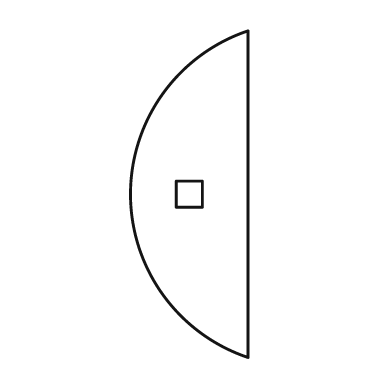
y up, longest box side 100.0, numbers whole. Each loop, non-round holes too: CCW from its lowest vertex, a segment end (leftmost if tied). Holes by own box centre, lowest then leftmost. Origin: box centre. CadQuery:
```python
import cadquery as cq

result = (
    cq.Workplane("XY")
    .moveTo(18.0, -50.0)
    .lineTo(18.0, 50.0)
    .threePointArc((-18.0, 0.0), (18.0, -50.0))
    .close()
    .moveTo(-4.0, -4.0)
    .lineTo(4.0, -4.0)
    .lineTo(4.0, 4.0)
    .lineTo(-4.0, 4.0)
    .close()
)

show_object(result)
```